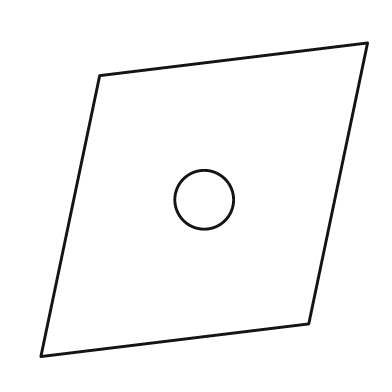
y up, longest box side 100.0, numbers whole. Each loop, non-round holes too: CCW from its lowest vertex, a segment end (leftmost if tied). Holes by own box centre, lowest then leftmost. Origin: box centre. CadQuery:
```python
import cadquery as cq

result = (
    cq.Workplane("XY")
    .moveTo(-50.0, -48.0)
    .lineTo(32.0, -38.0)
    .lineTo(50.0, 48.0)
    .lineTo(-32.0, 38.0)
    .close()
    .moveTo(0.0, 0.0)
    .circle(9.0)
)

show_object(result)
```